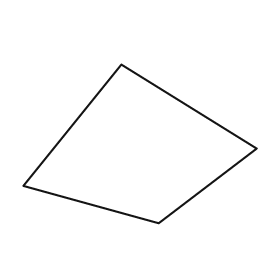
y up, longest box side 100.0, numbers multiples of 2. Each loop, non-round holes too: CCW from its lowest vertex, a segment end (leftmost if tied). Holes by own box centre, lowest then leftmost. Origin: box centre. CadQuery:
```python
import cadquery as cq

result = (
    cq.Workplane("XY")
    .moveTo(8.0, -34.0)
    .lineTo(50.0, -2.0)
    .lineTo(-8.0, 34.0)
    .lineTo(-50.0, -18.0)
    .close()
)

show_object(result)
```